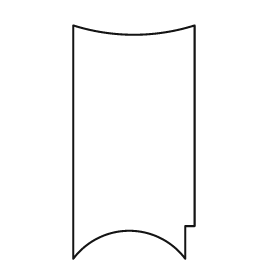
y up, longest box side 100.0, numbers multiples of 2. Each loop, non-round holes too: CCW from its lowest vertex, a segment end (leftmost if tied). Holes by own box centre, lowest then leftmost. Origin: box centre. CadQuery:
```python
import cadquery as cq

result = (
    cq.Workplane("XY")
    .moveTo(-26.0, -50.0)
    .threePointArc((-2.0, -38.0), (22.0, -50.0))
    .lineTo(22.0, -36.0)
    .lineTo(26.0, -36.0)
    .lineTo(26.0, 50.0)
    .threePointArc((0.0, 46.0), (-26.0, 50.0))
    .close()
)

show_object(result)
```